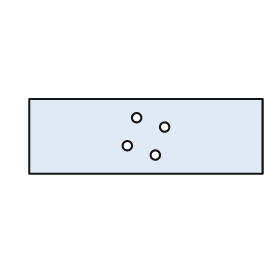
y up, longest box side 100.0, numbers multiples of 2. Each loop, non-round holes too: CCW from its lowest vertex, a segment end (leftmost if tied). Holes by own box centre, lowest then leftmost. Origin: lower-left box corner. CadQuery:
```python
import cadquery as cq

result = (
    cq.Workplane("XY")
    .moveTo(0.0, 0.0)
    .lineTo(100.0, 0.0)
    .lineTo(100.0, 32.0)
    .lineTo(0.0, 32.0)
    .close()
    .moveTo(54.0, 8.0)
    .circle(2.0)
    .moveTo(42.0, 12.0)
    .circle(2.0)
    .moveTo(58.0, 20.0)
    .circle(2.0)
    .moveTo(46.0, 24.0)
    .circle(2.0)
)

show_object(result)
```